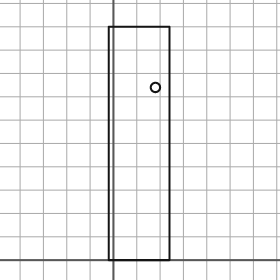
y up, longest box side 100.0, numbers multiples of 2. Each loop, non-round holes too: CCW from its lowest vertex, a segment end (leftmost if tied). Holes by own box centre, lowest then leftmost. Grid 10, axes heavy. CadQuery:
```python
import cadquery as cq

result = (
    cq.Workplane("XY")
    .moveTo(-2.0, 0.0)
    .lineTo(24.0, 0.0)
    .lineTo(24.0, 100.0)
    .lineTo(-2.0, 100.0)
    .close()
    .moveTo(18.0, 74.0)
    .circle(2.0)
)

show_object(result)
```